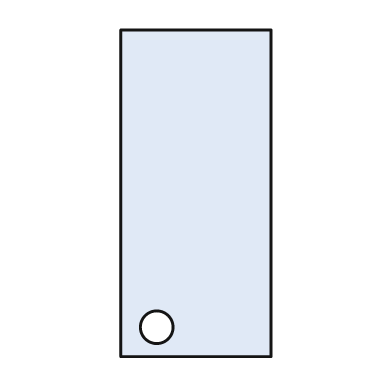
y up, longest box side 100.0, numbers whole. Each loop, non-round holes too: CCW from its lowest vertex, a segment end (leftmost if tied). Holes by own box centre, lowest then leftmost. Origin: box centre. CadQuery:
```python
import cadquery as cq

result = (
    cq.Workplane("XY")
    .moveTo(-23.0, -50.0)
    .lineTo(23.0, -50.0)
    .lineTo(23.0, 50.0)
    .lineTo(-23.0, 50.0)
    .close()
    .moveTo(-12.0, -41.0)
    .circle(5.0)
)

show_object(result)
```